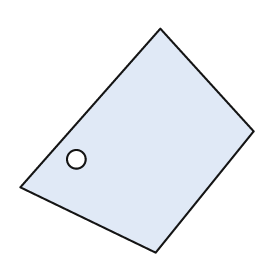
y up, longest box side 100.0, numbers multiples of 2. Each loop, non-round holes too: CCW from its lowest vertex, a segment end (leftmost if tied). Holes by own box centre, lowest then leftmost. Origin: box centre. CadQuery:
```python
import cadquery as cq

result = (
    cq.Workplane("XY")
    .moveTo(8.0, -48.0)
    .lineTo(50.0, 4.0)
    .lineTo(10.0, 48.0)
    .lineTo(-50.0, -20.0)
    .close()
    .moveTo(-26.0, -8.0)
    .circle(4.0)
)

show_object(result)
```